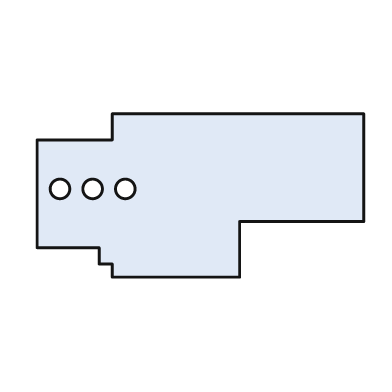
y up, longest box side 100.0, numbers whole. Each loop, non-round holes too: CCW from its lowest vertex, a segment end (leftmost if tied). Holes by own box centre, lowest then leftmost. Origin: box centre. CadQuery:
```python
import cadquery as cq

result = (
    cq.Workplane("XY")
    .moveTo(-27.0, -25.0)
    .lineTo(12.0, -25.0)
    .lineTo(12.0, -8.0)
    .lineTo(50.0, -8.0)
    .lineTo(50.0, 25.0)
    .lineTo(-27.0, 25.0)
    .lineTo(-27.0, 17.0)
    .lineTo(-50.0, 17.0)
    .lineTo(-50.0, -16.0)
    .lineTo(-31.0, -16.0)
    .lineTo(-31.0, -21.0)
    .lineTo(-27.0, -21.0)
    .close()
    .moveTo(-43.0, 2.0)
    .circle(3.0)
    .moveTo(-33.0, 2.0)
    .circle(3.0)
    .moveTo(-23.0, 2.0)
    .circle(3.0)
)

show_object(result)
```